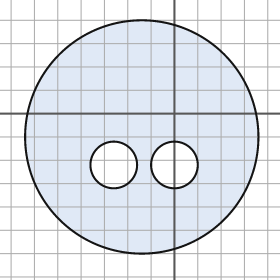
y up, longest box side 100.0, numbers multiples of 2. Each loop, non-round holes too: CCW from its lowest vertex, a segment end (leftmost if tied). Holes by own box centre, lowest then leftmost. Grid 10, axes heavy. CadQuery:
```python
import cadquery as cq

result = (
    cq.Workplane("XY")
    .moveTo(-14.0, -10.0)
    .circle(50.0)
    .moveTo(-26.0, -22.0)
    .circle(10.0)
    .moveTo(0.0, -22.0)
    .circle(10.0)
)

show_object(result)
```